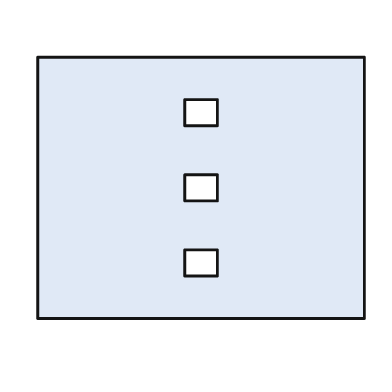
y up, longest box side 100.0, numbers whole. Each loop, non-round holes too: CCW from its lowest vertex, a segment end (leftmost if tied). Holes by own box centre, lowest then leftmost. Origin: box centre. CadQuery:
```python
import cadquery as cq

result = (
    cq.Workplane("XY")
    .moveTo(-50.0, -40.0)
    .lineTo(50.0, -40.0)
    .lineTo(50.0, 40.0)
    .lineTo(-50.0, 40.0)
    .close()
    .moveTo(-5.0, -27.0)
    .lineTo(5.0, -27.0)
    .lineTo(5.0, -19.0)
    .lineTo(-5.0, -19.0)
    .close()
    .moveTo(-5.0, -4.0)
    .lineTo(5.0, -4.0)
    .lineTo(5.0, 4.0)
    .lineTo(-5.0, 4.0)
    .close()
    .moveTo(-5.0, 19.0)
    .lineTo(5.0, 19.0)
    .lineTo(5.0, 27.0)
    .lineTo(-5.0, 27.0)
    .close()
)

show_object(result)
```